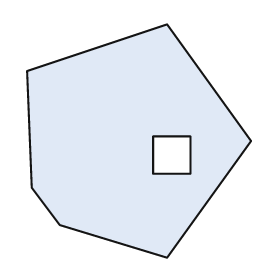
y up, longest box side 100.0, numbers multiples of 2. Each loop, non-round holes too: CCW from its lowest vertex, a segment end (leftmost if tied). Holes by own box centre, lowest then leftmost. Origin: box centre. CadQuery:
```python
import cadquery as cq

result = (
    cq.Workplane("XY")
    .moveTo(12.0, -50.0)
    .lineTo(48.0, 0.0)
    .lineTo(12.0, 50.0)
    .lineTo(-48.0, 30.0)
    .lineTo(-46.0, -20.0)
    .lineTo(-34.0, -36.0)
    .close()
    .moveTo(6.0, -14.0)
    .lineTo(22.0, -14.0)
    .lineTo(22.0, 2.0)
    .lineTo(6.0, 2.0)
    .close()
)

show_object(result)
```